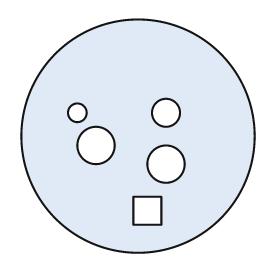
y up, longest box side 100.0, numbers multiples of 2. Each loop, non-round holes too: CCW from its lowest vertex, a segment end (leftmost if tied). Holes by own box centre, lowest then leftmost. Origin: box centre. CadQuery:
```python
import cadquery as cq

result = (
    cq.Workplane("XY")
    .moveTo(0.0, 0.0)
    .circle(50.0)
    .moveTo(-2.0, -38.0)
    .lineTo(10.0, -38.0)
    .lineTo(10.0, -26.0)
    .lineTo(-2.0, -26.0)
    .close()
    .moveTo(12.0, -12.0)
    .circle(8.0)
    .moveTo(-18.0, -4.0)
    .circle(8.0)
    .moveTo(-26.0, 10.0)
    .circle(4.0)
    .moveTo(12.0, 10.0)
    .circle(6.0)
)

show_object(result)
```